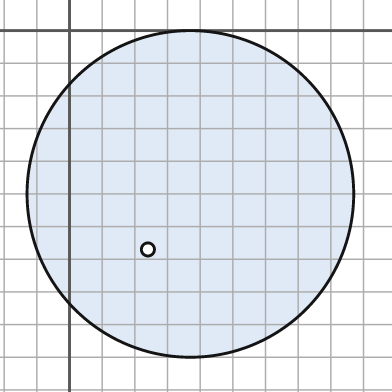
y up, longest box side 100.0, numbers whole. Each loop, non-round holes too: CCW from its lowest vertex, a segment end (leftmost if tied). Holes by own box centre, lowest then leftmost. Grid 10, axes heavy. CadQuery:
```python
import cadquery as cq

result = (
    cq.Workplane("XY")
    .moveTo(37.0, -50.0)
    .circle(50.0)
    .moveTo(24.0, -67.0)
    .circle(2.0)
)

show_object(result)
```